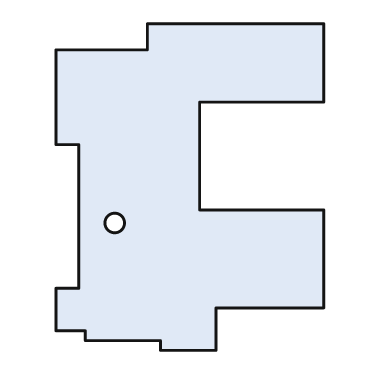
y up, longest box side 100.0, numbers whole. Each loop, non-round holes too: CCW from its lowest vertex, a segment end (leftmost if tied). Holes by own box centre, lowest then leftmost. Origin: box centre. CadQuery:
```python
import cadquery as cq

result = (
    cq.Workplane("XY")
    .moveTo(-9.0, -50.0)
    .lineTo(8.0, -50.0)
    .lineTo(8.0, -37.0)
    .lineTo(41.0, -37.0)
    .lineTo(41.0, -7.0)
    .lineTo(3.0, -7.0)
    .lineTo(3.0, 26.0)
    .lineTo(41.0, 26.0)
    .lineTo(41.0, 50.0)
    .lineTo(-13.0, 50.0)
    .lineTo(-13.0, 42.0)
    .lineTo(-41.0, 42.0)
    .lineTo(-41.0, 13.0)
    .lineTo(-34.0, 13.0)
    .lineTo(-34.0, -31.0)
    .lineTo(-41.0, -31.0)
    .lineTo(-41.0, -44.0)
    .lineTo(-32.0, -44.0)
    .lineTo(-32.0, -47.0)
    .lineTo(-9.0, -47.0)
    .close()
    .moveTo(-23.0, -11.0)
    .circle(3.0)
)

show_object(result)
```